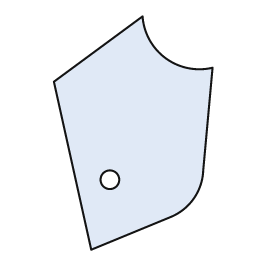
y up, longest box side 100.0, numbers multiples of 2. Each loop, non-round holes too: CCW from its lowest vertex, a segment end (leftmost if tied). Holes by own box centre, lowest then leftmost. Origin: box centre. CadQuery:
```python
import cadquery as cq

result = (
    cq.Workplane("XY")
    .moveTo(-18.0, -50.0)
    .lineTo(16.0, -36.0)
    .threePointArc((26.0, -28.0), (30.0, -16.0))
    .lineTo(34.0, 28.0)
    .threePointArc((14.0, 32.0), (4.0, 50.0))
    .lineTo(-34.0, 22.0)
    .close()
    .moveTo(-10.0, -20.0)
    .circle(4.0)
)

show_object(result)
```